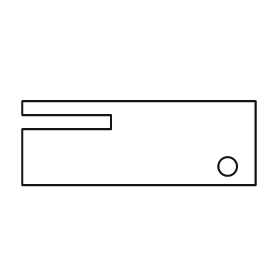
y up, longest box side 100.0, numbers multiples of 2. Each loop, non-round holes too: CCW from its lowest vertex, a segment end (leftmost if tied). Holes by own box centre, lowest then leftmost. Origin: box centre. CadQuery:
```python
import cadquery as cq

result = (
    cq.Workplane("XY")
    .moveTo(-50.0, -18.0)
    .lineTo(50.0, -18.0)
    .lineTo(50.0, 18.0)
    .lineTo(-50.0, 18.0)
    .lineTo(-50.0, 12.0)
    .lineTo(-12.0, 12.0)
    .lineTo(-12.0, 6.0)
    .lineTo(-50.0, 6.0)
    .close()
    .moveTo(38.0, -10.0)
    .circle(4.0)
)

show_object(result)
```